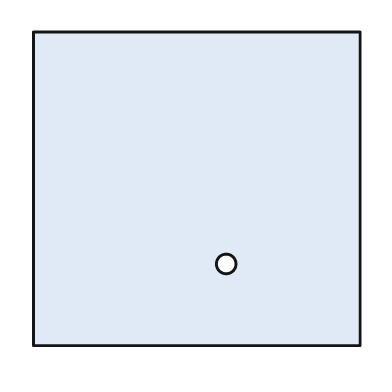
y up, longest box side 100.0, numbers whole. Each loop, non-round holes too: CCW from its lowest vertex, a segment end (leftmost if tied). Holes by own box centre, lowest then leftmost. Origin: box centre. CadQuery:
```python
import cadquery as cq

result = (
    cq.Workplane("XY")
    .moveTo(-50.0, -48.0)
    .lineTo(50.0, -48.0)
    .lineTo(50.0, 48.0)
    .lineTo(-50.0, 48.0)
    .close()
    .moveTo(9.0, -23.0)
    .circle(3.0)
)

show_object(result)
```